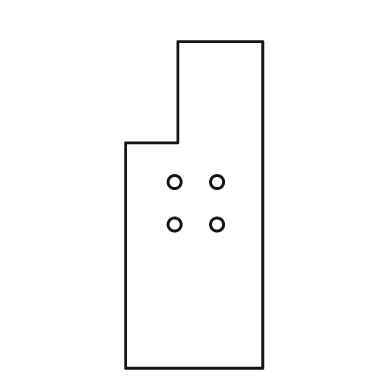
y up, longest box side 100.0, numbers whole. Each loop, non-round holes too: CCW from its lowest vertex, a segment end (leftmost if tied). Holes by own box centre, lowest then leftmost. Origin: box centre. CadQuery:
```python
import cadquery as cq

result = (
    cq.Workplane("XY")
    .moveTo(-21.0, -50.0)
    .lineTo(21.0, -50.0)
    .lineTo(21.0, 50.0)
    .lineTo(-5.0, 50.0)
    .lineTo(-5.0, 19.0)
    .lineTo(-21.0, 19.0)
    .close()
    .moveTo(-6.0, -6.0)
    .circle(2.0)
    .moveTo(7.0, -6.0)
    .circle(2.0)
    .moveTo(-6.0, 7.0)
    .circle(2.0)
    .moveTo(7.0, 7.0)
    .circle(2.0)
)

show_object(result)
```